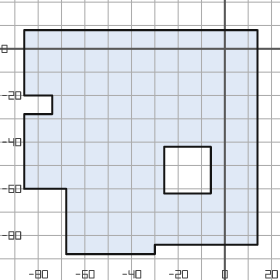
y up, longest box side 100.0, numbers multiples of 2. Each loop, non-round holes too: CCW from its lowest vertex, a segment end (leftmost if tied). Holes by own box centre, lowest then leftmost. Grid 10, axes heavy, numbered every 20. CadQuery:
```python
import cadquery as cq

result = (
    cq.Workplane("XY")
    .moveTo(-68.0, -88.0)
    .lineTo(-30.0, -88.0)
    .lineTo(-30.0, -84.0)
    .lineTo(14.0, -84.0)
    .lineTo(14.0, 8.0)
    .lineTo(-86.0, 8.0)
    .lineTo(-86.0, -20.0)
    .lineTo(-74.0, -20.0)
    .lineTo(-74.0, -28.0)
    .lineTo(-86.0, -28.0)
    .lineTo(-86.0, -60.0)
    .lineTo(-68.0, -60.0)
    .close()
    .moveTo(-26.0, -62.0)
    .lineTo(-6.0, -62.0)
    .lineTo(-6.0, -42.0)
    .lineTo(-26.0, -42.0)
    .close()
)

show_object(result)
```